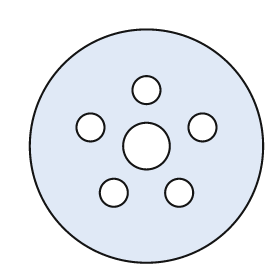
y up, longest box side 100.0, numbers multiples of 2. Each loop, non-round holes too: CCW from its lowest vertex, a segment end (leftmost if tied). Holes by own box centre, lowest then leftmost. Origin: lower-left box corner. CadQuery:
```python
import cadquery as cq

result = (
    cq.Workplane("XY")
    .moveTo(50.0, 50.0)
    .circle(50.0)
    .moveTo(36.0, 30.0)
    .circle(6.0)
    .moveTo(64.0, 30.0)
    .circle(6.0)
    .moveTo(50.0, 50.0)
    .circle(10.0)
    .moveTo(26.0, 58.0)
    .circle(6.0)
    .moveTo(74.0, 58.0)
    .circle(6.0)
    .moveTo(50.0, 74.0)
    .circle(6.0)
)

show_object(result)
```